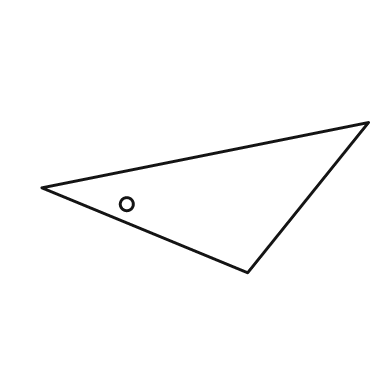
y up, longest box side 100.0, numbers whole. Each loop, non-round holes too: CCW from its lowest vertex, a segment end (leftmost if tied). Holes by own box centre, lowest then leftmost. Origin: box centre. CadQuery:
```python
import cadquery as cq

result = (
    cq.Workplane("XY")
    .moveTo(13.0, -23.0)
    .lineTo(50.0, 23.0)
    .lineTo(-50.0, 3.0)
    .close()
    .moveTo(-24.0, -2.0)
    .circle(2.0)
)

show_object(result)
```